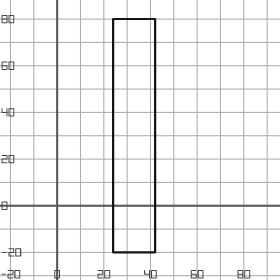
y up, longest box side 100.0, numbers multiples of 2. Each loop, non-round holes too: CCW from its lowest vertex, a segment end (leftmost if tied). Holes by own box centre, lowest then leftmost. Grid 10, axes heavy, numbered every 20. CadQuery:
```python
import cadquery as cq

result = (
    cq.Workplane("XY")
    .moveTo(24.0, -20.0)
    .lineTo(42.0, -20.0)
    .lineTo(42.0, 80.0)
    .lineTo(24.0, 80.0)
    .close()
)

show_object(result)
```